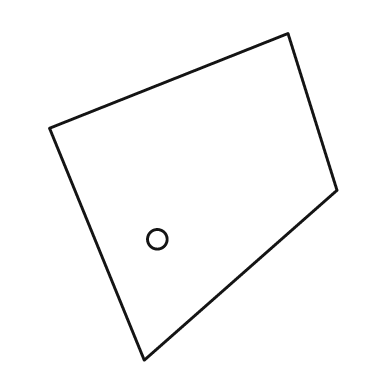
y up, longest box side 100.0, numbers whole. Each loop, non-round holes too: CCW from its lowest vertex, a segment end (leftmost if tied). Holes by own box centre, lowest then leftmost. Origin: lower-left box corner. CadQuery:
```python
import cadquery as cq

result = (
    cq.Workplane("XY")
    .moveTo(29.0, 0.0)
    .lineTo(88.0, 52.0)
    .lineTo(73.0, 100.0)
    .lineTo(0.0, 71.0)
    .close()
    .moveTo(33.0, 37.0)
    .circle(3.0)
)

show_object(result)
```